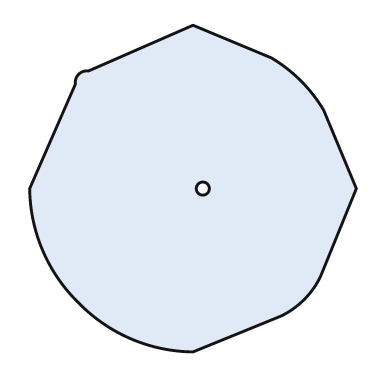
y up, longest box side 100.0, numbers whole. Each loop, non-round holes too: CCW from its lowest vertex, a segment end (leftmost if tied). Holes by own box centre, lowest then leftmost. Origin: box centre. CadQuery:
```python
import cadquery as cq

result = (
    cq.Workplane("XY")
    .moveTo(0.0, -50.0)
    .lineTo(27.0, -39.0)
    .threePointArc((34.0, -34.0), (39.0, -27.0))
    .lineTo(50.0, 0.0)
    .lineTo(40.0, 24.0)
    .threePointArc((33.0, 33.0), (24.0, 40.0))
    .lineTo(0.0, 50.0)
    .lineTo(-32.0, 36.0)
    .threePointArc((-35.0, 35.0), (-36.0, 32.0))
    .lineTo(-50.0, 0.0)
    .threePointArc((-46.0, -19.0), (-35.0, -35.0))
    .threePointArc((-19.0, -46.0), (0.0, -50.0))
    .close()
    .moveTo(3.0, 0.0)
    .circle(2.0)
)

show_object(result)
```